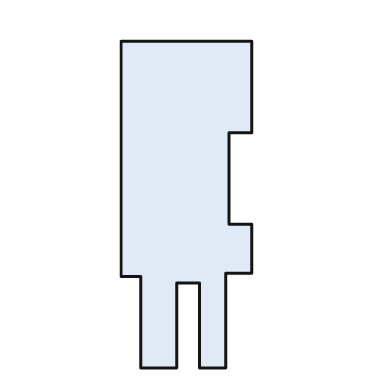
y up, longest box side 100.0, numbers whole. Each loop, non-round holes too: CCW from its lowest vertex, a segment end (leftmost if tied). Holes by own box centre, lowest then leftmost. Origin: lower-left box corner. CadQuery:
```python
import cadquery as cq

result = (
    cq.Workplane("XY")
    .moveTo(6.0, 0.0)
    .lineTo(17.0, 0.0)
    .lineTo(17.0, 26.0)
    .lineTo(24.0, 26.0)
    .lineTo(24.0, 0.0)
    .lineTo(32.0, 0.0)
    .lineTo(32.0, 29.0)
    .lineTo(40.0, 29.0)
    .lineTo(40.0, 44.0)
    .lineTo(33.0, 44.0)
    .lineTo(33.0, 72.0)
    .lineTo(40.0, 72.0)
    .lineTo(40.0, 100.0)
    .lineTo(0.0, 100.0)
    .lineTo(0.0, 28.0)
    .lineTo(6.0, 28.0)
    .close()
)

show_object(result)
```